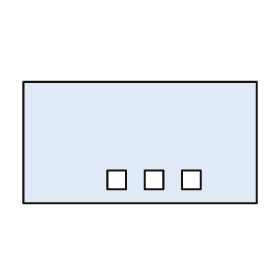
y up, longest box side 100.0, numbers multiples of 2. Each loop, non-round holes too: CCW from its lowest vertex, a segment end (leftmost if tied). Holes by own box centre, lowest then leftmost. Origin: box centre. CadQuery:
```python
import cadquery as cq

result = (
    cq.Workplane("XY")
    .moveTo(-50.0, -26.0)
    .lineTo(50.0, -26.0)
    .lineTo(50.0, 26.0)
    .lineTo(-50.0, 26.0)
    .close()
    .moveTo(-14.0, -20.0)
    .lineTo(-6.0, -20.0)
    .lineTo(-6.0, -12.0)
    .lineTo(-14.0, -12.0)
    .close()
    .moveTo(2.0, -20.0)
    .lineTo(10.0, -20.0)
    .lineTo(10.0, -12.0)
    .lineTo(2.0, -12.0)
    .close()
    .moveTo(18.0, -20.0)
    .lineTo(26.0, -20.0)
    .lineTo(26.0, -12.0)
    .lineTo(18.0, -12.0)
    .close()
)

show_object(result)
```